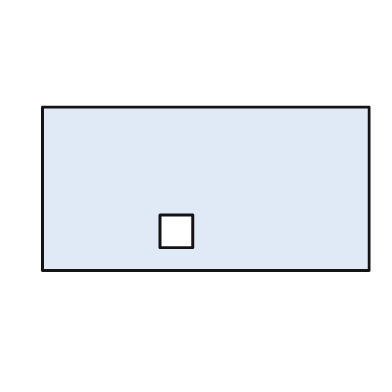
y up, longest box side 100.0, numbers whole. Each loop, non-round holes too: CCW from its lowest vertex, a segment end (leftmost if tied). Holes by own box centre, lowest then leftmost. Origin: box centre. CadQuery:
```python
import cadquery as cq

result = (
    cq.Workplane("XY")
    .moveTo(-50.0, -25.0)
    .lineTo(50.0, -25.0)
    .lineTo(50.0, 25.0)
    .lineTo(-50.0, 25.0)
    .close()
    .moveTo(-14.0, -18.0)
    .lineTo(-4.0, -18.0)
    .lineTo(-4.0, -8.0)
    .lineTo(-14.0, -8.0)
    .close()
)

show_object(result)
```